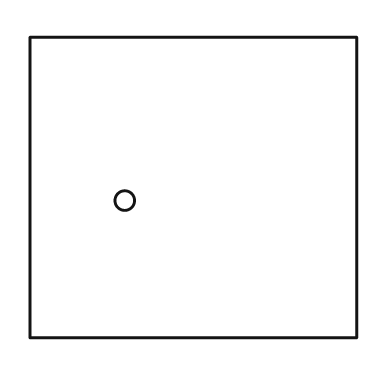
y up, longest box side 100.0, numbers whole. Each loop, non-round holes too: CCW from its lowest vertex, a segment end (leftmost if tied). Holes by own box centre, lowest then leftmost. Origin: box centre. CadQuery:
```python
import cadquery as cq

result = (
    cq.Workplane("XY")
    .moveTo(-50.0, -46.0)
    .lineTo(50.0, -46.0)
    .lineTo(50.0, 46.0)
    .lineTo(-50.0, 46.0)
    .close()
    .moveTo(-21.0, -4.0)
    .circle(3.0)
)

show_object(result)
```